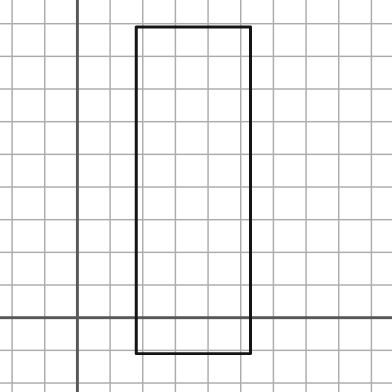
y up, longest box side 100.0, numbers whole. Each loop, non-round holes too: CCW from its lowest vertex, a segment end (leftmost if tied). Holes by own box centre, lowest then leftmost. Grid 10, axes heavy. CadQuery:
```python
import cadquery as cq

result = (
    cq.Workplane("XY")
    .moveTo(18.0, -11.0)
    .lineTo(53.0, -11.0)
    .lineTo(53.0, 89.0)
    .lineTo(18.0, 89.0)
    .close()
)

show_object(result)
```